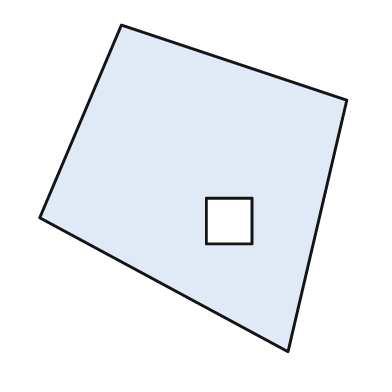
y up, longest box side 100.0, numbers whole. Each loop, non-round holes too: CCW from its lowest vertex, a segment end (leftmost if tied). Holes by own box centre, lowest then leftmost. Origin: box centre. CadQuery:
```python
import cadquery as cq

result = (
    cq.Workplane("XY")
    .moveTo(29.0, -50.0)
    .lineTo(47.0, 27.0)
    .lineTo(-22.0, 50.0)
    .lineTo(-47.0, -9.0)
    .close()
    .moveTo(4.0, -17.0)
    .lineTo(18.0, -17.0)
    .lineTo(18.0, -3.0)
    .lineTo(4.0, -3.0)
    .close()
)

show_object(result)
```